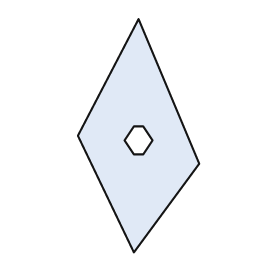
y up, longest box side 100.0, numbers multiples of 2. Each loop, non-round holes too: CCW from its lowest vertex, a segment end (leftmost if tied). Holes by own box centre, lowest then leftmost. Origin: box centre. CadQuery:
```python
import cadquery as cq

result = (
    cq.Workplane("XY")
    .moveTo(-2.0, -50.0)
    .lineTo(26.0, -12.0)
    .lineTo(0.0, 50.0)
    .lineTo(-26.0, 0.0)
    .close()
    .moveTo(-2.0, -8.0)
    .lineTo(2.0, -8.0)
    .lineTo(6.0, -2.0)
    .lineTo(2.0, 4.0)
    .lineTo(-2.0, 4.0)
    .lineTo(-6.0, -2.0)
    .close()
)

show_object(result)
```